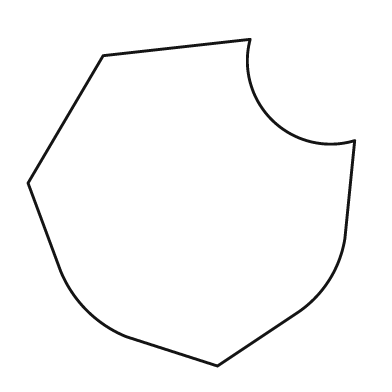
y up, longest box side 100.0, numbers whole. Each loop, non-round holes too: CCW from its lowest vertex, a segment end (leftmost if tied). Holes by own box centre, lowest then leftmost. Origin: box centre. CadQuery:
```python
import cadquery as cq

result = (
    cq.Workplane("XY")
    .moveTo(8.0, -50.0)
    .lineTo(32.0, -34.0)
    .threePointArc((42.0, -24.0), (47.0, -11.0))
    .lineTo(50.0, 19.0)
    .threePointArc((25.0, 25.0), (18.0, 50.0))
    .lineTo(-27.0, 45.0)
    .lineTo(-50.0, 6.0)
    .lineTo(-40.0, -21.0)
    .threePointArc((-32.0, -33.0), (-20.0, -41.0))
    .close()
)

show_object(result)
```